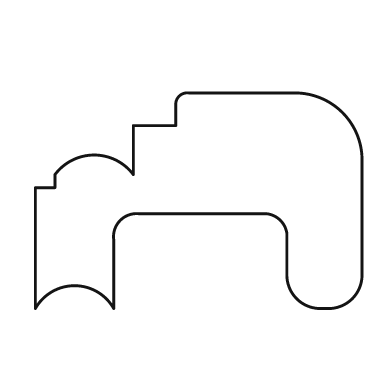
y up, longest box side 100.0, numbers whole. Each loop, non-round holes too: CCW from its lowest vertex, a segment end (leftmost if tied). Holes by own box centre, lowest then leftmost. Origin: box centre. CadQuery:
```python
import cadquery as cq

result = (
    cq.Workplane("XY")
    .moveTo(-50.0, -33.0)
    .threePointArc((-38.0, -26.0), (-26.0, -33.0))
    .lineTo(-26.0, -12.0)
    .threePointArc((-24.0, -6.0), (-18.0, -4.0))
    .lineTo(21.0, -4.0)
    .threePointArc((25.0, -6.0), (27.0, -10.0))
    .lineTo(27.0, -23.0)
    .threePointArc((30.0, -30.0), (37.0, -33.0))
    .lineTo(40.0, -33.0)
    .threePointArc((47.0, -30.0), (50.0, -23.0))
    .lineTo(50.0, 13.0)
    .threePointArc((44.0, 27.0), (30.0, 33.0))
    .lineTo(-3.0, 33.0)
    .threePointArc((-6.0, 32.0), (-7.0, 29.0))
    .lineTo(-7.0, 23.0)
    .lineTo(-20.0, 23.0)
    .lineTo(-20.0, 8.0)
    .threePointArc((-32.0, 14.0), (-44.0, 8.0))
    .lineTo(-44.0, 4.0)
    .lineTo(-50.0, 4.0)
    .close()
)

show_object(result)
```